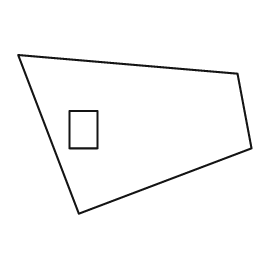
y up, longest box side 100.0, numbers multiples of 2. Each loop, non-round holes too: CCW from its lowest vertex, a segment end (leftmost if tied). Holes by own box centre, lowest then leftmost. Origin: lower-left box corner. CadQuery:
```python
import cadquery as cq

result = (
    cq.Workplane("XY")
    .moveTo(26.0, 0.0)
    .lineTo(100.0, 28.0)
    .lineTo(94.0, 60.0)
    .lineTo(0.0, 68.0)
    .close()
    .moveTo(22.0, 28.0)
    .lineTo(34.0, 28.0)
    .lineTo(34.0, 44.0)
    .lineTo(22.0, 44.0)
    .close()
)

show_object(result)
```